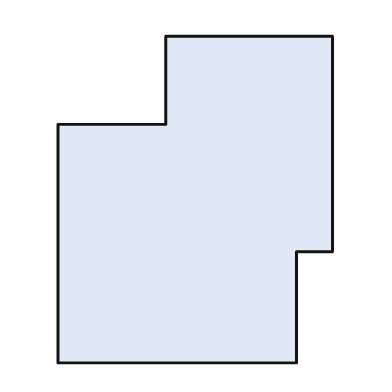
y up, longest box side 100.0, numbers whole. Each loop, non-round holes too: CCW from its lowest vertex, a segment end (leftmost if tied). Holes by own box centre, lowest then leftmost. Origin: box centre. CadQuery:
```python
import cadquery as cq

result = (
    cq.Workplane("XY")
    .moveTo(-42.0, -50.0)
    .lineTo(31.0, -50.0)
    .lineTo(31.0, -16.0)
    .lineTo(42.0, -16.0)
    .lineTo(42.0, 50.0)
    .lineTo(-9.0, 50.0)
    .lineTo(-9.0, 23.0)
    .lineTo(-42.0, 23.0)
    .close()
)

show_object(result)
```